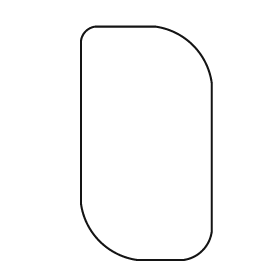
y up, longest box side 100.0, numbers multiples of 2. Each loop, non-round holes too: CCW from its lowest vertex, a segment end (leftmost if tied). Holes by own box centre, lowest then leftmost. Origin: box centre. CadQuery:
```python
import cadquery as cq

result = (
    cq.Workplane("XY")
    .moveTo(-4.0, -50.0)
    .lineTo(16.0, -50.0)
    .threePointArc((24.0, -46.0), (28.0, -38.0))
    .lineTo(28.0, 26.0)
    .threePointArc((20.0, 42.0), (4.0, 50.0))
    .lineTo(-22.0, 50.0)
    .threePointArc((-26.0, 48.0), (-28.0, 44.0))
    .lineTo(-28.0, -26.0)
    .threePointArc((-20.0, -42.0), (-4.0, -50.0))
    .close()
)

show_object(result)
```